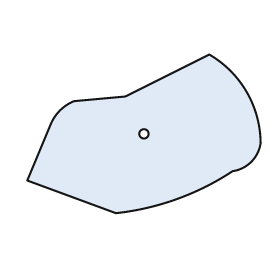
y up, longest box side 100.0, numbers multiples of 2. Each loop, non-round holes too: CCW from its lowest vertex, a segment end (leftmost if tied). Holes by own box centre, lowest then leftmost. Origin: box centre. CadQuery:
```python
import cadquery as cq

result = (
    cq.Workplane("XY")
    .moveTo(-12.0, -34.0)
    .threePointArc((14.0, -28.0), (38.0, -16.0))
    .threePointArc((46.0, -12.0), (50.0, -4.0))
    .threePointArc((44.0, 18.0), (28.0, 34.0))
    .lineTo(-8.0, 16.0)
    .lineTo(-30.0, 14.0)
    .threePointArc((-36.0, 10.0), (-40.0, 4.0))
    .lineTo(-50.0, -20.0)
    .close()
    .moveTo(0.0, 0.0)
    .circle(2.0)
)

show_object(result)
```